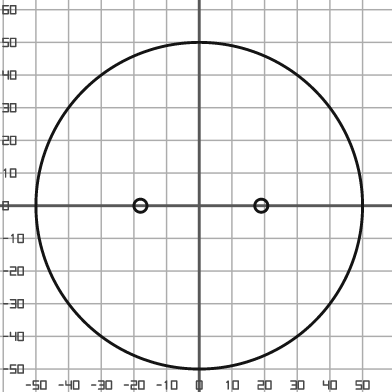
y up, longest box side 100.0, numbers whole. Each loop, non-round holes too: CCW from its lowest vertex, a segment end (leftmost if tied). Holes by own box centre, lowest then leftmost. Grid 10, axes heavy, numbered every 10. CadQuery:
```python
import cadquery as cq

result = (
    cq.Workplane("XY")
    .moveTo(0.0, 0.0)
    .circle(50.0)
    .moveTo(-18.0, 0.0)
    .circle(2.0)
    .moveTo(19.0, 0.0)
    .circle(2.0)
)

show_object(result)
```